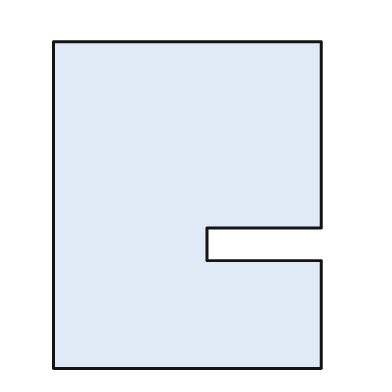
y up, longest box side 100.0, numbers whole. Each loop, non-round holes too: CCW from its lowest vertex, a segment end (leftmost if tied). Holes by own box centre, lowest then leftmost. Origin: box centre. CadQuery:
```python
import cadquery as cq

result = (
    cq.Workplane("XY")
    .moveTo(-41.0, -50.0)
    .lineTo(41.0, -50.0)
    .lineTo(41.0, -17.0)
    .lineTo(6.0, -17.0)
    .lineTo(6.0, -7.0)
    .lineTo(41.0, -7.0)
    .lineTo(41.0, 50.0)
    .lineTo(-41.0, 50.0)
    .close()
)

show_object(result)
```